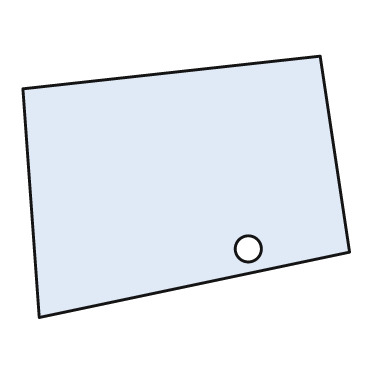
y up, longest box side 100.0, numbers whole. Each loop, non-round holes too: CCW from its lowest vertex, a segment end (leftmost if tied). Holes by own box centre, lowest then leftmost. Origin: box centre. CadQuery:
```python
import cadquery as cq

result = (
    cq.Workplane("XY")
    .moveTo(-45.0, -40.0)
    .lineTo(50.0, -20.0)
    .lineTo(41.0, 40.0)
    .lineTo(-50.0, 30.0)
    .close()
    .moveTo(19.0, -19.0)
    .circle(4.0)
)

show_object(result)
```